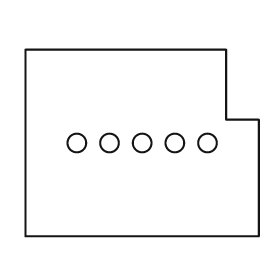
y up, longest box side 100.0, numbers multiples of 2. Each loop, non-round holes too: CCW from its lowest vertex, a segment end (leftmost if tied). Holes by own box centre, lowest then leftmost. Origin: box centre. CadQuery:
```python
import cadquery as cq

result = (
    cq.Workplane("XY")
    .moveTo(-50.0, -40.0)
    .lineTo(50.0, -40.0)
    .lineTo(50.0, 10.0)
    .lineTo(36.0, 10.0)
    .lineTo(36.0, 40.0)
    .lineTo(-50.0, 40.0)
    .close()
    .moveTo(-28.0, 0.0)
    .circle(4.0)
    .moveTo(-14.0, 0.0)
    .circle(4.0)
    .moveTo(0.0, 0.0)
    .circle(4.0)
    .moveTo(14.0, 0.0)
    .circle(4.0)
    .moveTo(28.0, 0.0)
    .circle(4.0)
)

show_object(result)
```